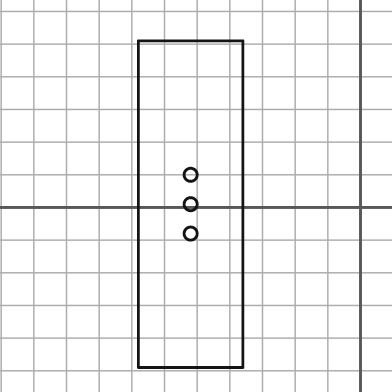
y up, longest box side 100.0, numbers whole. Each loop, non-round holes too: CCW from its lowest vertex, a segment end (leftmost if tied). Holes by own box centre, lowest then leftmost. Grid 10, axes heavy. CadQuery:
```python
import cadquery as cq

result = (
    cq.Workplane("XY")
    .moveTo(-68.0, -49.0)
    .lineTo(-36.0, -49.0)
    .lineTo(-36.0, 51.0)
    .lineTo(-68.0, 51.0)
    .close()
    .moveTo(-52.0, -8.0)
    .circle(2.0)
    .moveTo(-52.0, 1.0)
    .circle(2.0)
    .moveTo(-52.0, 10.0)
    .circle(2.0)
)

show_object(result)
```